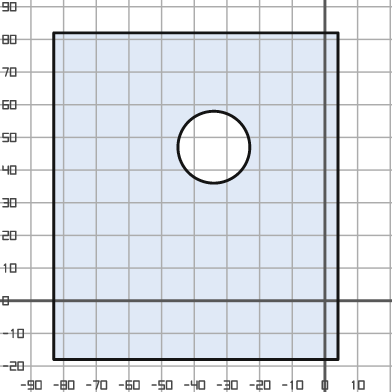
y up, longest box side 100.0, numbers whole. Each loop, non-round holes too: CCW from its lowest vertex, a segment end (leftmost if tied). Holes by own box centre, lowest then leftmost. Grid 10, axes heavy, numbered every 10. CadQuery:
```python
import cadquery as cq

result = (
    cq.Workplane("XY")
    .moveTo(-83.0, -18.0)
    .lineTo(4.0, -18.0)
    .lineTo(4.0, 82.0)
    .lineTo(-83.0, 82.0)
    .close()
    .moveTo(-34.0, 47.0)
    .circle(11.0)
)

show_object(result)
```